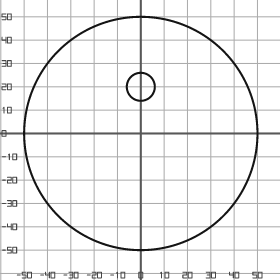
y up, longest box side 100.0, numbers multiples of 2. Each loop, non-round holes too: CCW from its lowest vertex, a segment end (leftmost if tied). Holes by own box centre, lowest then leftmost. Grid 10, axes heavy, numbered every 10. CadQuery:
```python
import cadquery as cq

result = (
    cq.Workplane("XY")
    .moveTo(0.0, 0.0)
    .circle(50.0)
    .moveTo(0.0, 20.0)
    .circle(6.0)
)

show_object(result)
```